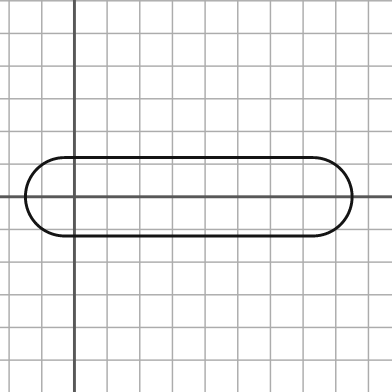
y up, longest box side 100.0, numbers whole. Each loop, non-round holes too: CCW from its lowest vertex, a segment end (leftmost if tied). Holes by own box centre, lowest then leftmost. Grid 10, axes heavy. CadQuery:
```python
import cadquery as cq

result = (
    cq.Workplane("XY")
    .moveTo(-3.0, -12.0)
    .lineTo(73.0, -12.0)
    .threePointArc((85.0, 0.0), (73.0, 12.0))
    .lineTo(-3.0, 12.0)
    .threePointArc((-15.0, 0.0), (-3.0, -12.0))
    .close()
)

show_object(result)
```